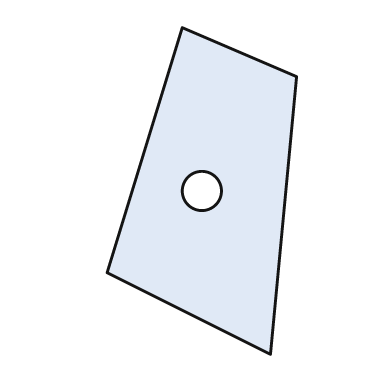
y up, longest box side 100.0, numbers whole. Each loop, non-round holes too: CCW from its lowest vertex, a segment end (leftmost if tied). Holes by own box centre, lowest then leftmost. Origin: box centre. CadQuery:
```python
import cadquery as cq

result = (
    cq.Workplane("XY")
    .moveTo(21.0, -50.0)
    .lineTo(29.0, 35.0)
    .lineTo(-6.0, 50.0)
    .lineTo(-29.0, -25.0)
    .close()
    .moveTo(0.0, 0.0)
    .circle(6.0)
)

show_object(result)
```